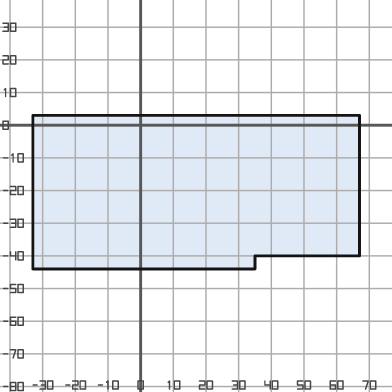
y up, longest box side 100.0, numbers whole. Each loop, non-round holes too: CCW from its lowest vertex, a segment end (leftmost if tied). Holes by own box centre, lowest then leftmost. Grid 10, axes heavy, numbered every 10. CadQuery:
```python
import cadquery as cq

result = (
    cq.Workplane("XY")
    .moveTo(-33.0, -44.0)
    .lineTo(35.0, -44.0)
    .lineTo(35.0, -40.0)
    .lineTo(67.0, -40.0)
    .lineTo(67.0, 3.0)
    .lineTo(-33.0, 3.0)
    .close()
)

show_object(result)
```